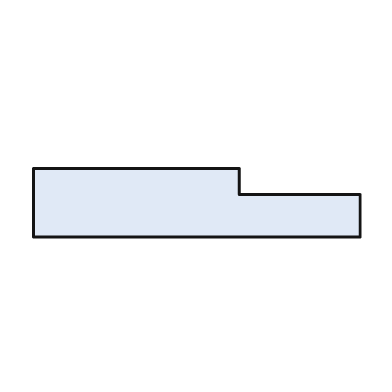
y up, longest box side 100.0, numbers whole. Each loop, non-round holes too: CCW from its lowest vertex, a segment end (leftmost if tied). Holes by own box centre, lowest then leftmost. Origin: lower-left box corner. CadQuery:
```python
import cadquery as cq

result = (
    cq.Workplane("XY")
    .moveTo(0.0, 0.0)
    .lineTo(100.0, 0.0)
    .lineTo(100.0, 13.0)
    .lineTo(63.0, 13.0)
    .lineTo(63.0, 21.0)
    .lineTo(0.0, 21.0)
    .close()
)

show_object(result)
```